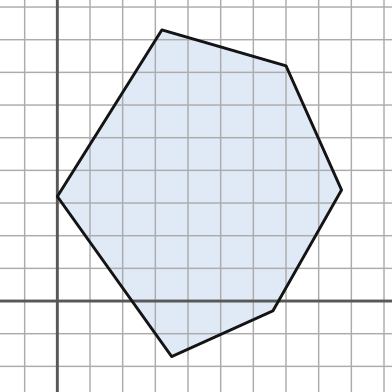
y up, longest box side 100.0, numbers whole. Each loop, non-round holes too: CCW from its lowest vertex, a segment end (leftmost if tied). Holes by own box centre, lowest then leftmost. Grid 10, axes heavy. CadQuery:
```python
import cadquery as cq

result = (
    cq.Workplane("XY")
    .moveTo(35.0, -17.0)
    .lineTo(66.0, -3.0)
    .lineTo(87.0, 34.0)
    .lineTo(70.0, 72.0)
    .lineTo(32.0, 83.0)
    .lineTo(0.0, 32.0)
    .close()
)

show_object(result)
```